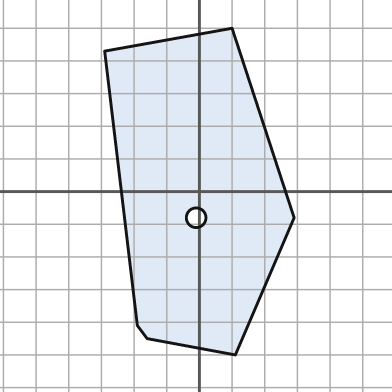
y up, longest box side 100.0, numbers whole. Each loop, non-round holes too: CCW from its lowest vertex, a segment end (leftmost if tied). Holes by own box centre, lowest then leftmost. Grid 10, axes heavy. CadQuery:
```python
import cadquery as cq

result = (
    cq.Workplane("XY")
    .moveTo(11.0, -50.0)
    .lineTo(29.0, -8.0)
    .lineTo(10.0, 50.0)
    .lineTo(-29.0, 43.0)
    .lineTo(-19.0, -41.0)
    .lineTo(-16.0, -45.0)
    .close()
    .moveTo(-1.0, -8.0)
    .circle(3.0)
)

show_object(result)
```